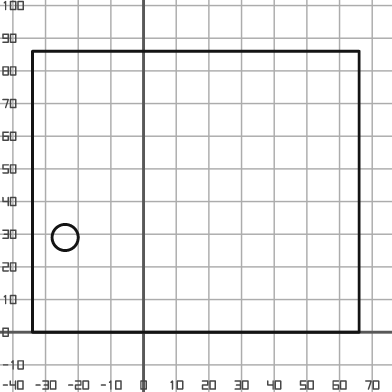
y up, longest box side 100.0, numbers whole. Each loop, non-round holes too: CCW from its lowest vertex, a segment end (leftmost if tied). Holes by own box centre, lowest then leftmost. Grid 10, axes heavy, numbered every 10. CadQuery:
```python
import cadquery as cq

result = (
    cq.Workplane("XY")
    .moveTo(-34.0, 0.0)
    .lineTo(66.0, 0.0)
    .lineTo(66.0, 86.0)
    .lineTo(-34.0, 86.0)
    .close()
    .moveTo(-24.0, 29.0)
    .circle(4.0)
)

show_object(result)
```